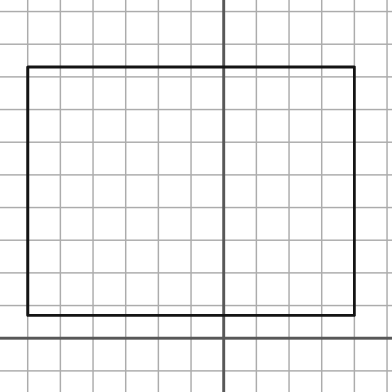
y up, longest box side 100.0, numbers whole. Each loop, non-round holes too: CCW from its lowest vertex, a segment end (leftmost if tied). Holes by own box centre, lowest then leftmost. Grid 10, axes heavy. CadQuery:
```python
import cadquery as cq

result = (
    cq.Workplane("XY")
    .moveTo(-60.0, 7.0)
    .lineTo(40.0, 7.0)
    .lineTo(40.0, 83.0)
    .lineTo(-60.0, 83.0)
    .close()
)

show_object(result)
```